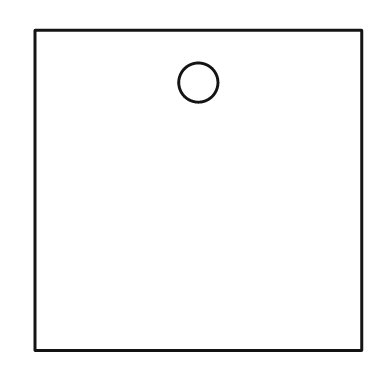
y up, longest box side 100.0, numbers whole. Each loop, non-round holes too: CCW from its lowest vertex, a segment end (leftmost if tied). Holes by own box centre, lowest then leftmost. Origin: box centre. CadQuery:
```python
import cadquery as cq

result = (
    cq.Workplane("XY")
    .moveTo(-50.0, -49.0)
    .lineTo(50.0, -49.0)
    .lineTo(50.0, 49.0)
    .lineTo(-50.0, 49.0)
    .close()
    .moveTo(0.0, 33.0)
    .circle(6.0)
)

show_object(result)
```